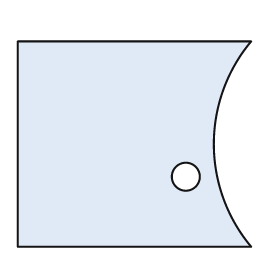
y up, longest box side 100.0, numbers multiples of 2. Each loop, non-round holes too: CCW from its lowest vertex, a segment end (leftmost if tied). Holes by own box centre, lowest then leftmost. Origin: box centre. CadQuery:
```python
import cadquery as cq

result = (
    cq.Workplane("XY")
    .moveTo(-50.0, -44.0)
    .lineTo(50.0, -44.0)
    .threePointArc((34.0, 0.0), (50.0, 44.0))
    .lineTo(-50.0, 44.0)
    .close()
    .moveTo(22.0, -14.0)
    .circle(6.0)
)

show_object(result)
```